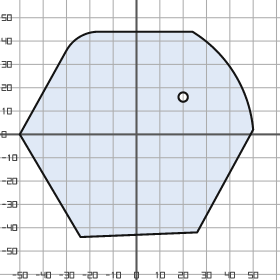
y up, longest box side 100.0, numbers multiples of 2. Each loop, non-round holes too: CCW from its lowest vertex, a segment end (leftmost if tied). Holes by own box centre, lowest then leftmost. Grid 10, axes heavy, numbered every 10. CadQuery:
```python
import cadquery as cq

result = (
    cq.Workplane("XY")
    .moveTo(-24.0, -44.0)
    .lineTo(26.0, -42.0)
    .lineTo(50.0, 2.0)
    .threePointArc((42.0, 26.0), (24.0, 44.0))
    .lineTo(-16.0, 44.0)
    .threePointArc((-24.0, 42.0), (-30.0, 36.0))
    .lineTo(-50.0, 0.0)
    .close()
    .moveTo(20.0, 16.0)
    .circle(2.0)
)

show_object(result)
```